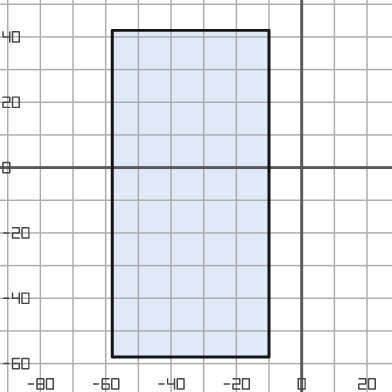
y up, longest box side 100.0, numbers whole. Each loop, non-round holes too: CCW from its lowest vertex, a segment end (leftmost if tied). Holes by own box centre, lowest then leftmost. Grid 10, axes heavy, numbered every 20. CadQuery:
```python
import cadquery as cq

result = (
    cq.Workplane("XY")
    .moveTo(-58.0, -58.0)
    .lineTo(-10.0, -58.0)
    .lineTo(-10.0, 42.0)
    .lineTo(-58.0, 42.0)
    .close()
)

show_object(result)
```